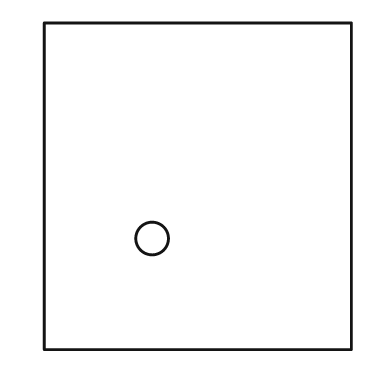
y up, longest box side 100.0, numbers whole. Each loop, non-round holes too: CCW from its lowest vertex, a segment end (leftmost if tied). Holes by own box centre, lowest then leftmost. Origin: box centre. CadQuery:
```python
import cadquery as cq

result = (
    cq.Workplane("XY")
    .moveTo(-47.0, -50.0)
    .lineTo(47.0, -50.0)
    .lineTo(47.0, 50.0)
    .lineTo(-47.0, 50.0)
    .close()
    .moveTo(-14.0, -16.0)
    .circle(5.0)
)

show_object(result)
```